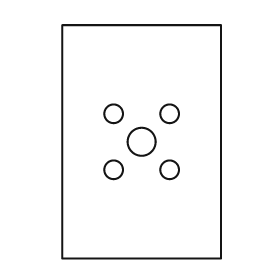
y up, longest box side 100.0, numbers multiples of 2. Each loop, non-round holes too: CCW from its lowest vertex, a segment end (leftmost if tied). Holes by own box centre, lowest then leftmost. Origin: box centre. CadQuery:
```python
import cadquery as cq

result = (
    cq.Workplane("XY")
    .moveTo(-34.0, -50.0)
    .lineTo(34.0, -50.0)
    .lineTo(34.0, 50.0)
    .lineTo(-34.0, 50.0)
    .close()
    .moveTo(-12.0, -12.0)
    .circle(4.0)
    .moveTo(12.0, -12.0)
    .circle(4.0)
    .moveTo(0.0, 0.0)
    .circle(6.0)
    .moveTo(-12.0, 12.0)
    .circle(4.0)
    .moveTo(12.0, 12.0)
    .circle(4.0)
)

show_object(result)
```